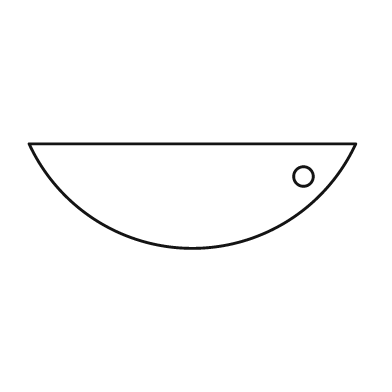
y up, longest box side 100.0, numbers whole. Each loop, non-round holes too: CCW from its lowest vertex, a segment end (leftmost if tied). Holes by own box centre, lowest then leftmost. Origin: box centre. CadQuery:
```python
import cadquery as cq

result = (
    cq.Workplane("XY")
    .moveTo(-50.0, 16.0)
    .threePointArc((0.0, -16.0), (50.0, 16.0))
    .close()
    .moveTo(34.0, 6.0)
    .circle(3.0)
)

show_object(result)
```